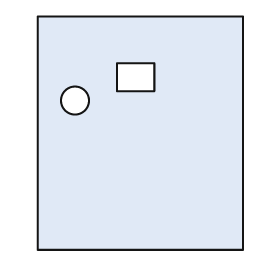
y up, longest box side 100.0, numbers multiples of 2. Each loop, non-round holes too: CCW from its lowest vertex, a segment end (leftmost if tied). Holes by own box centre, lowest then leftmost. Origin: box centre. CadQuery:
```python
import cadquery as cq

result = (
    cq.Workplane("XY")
    .moveTo(-44.0, -50.0)
    .lineTo(44.0, -50.0)
    .lineTo(44.0, 50.0)
    .lineTo(-44.0, 50.0)
    .close()
    .moveTo(-28.0, 14.0)
    .circle(6.0)
    .moveTo(-10.0, 18.0)
    .lineTo(6.0, 18.0)
    .lineTo(6.0, 30.0)
    .lineTo(-10.0, 30.0)
    .close()
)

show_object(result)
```